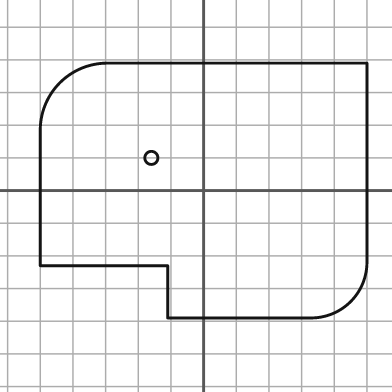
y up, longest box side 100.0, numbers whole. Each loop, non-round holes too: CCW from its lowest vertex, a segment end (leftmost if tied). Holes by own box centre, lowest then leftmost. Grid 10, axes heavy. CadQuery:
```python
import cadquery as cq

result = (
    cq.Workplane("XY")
    .moveTo(-11.0, -39.0)
    .lineTo(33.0, -39.0)
    .threePointArc((45.0, -34.0), (50.0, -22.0))
    .lineTo(50.0, 39.0)
    .lineTo(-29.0, 39.0)
    .threePointArc((-44.0, 33.0), (-50.0, 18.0))
    .lineTo(-50.0, -23.0)
    .lineTo(-11.0, -23.0)
    .close()
    .moveTo(-16.0, 10.0)
    .circle(2.0)
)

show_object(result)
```